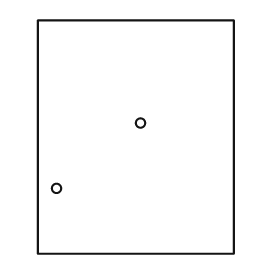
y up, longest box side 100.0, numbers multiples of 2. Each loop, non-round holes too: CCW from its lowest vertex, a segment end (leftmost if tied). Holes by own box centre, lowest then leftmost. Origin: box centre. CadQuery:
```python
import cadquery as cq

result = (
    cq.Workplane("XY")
    .moveTo(-42.0, -50.0)
    .lineTo(42.0, -50.0)
    .lineTo(42.0, 50.0)
    .lineTo(-42.0, 50.0)
    .close()
    .moveTo(-34.0, -22.0)
    .circle(2.0)
    .moveTo(2.0, 6.0)
    .circle(2.0)
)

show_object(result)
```